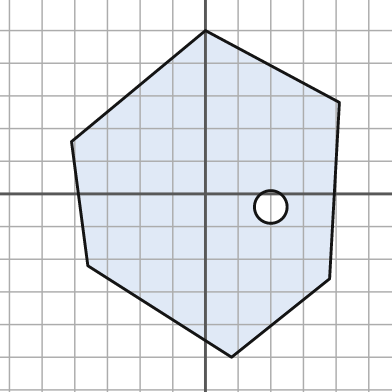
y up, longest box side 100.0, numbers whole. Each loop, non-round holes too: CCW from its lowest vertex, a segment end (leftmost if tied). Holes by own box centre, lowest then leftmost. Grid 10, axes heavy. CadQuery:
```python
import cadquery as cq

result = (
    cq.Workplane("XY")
    .moveTo(8.0, -50.0)
    .lineTo(38.0, -26.0)
    .lineTo(41.0, 28.0)
    .lineTo(0.0, 50.0)
    .lineTo(-41.0, 16.0)
    .lineTo(-36.0, -22.0)
    .close()
    .moveTo(20.0, -4.0)
    .circle(5.0)
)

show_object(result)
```